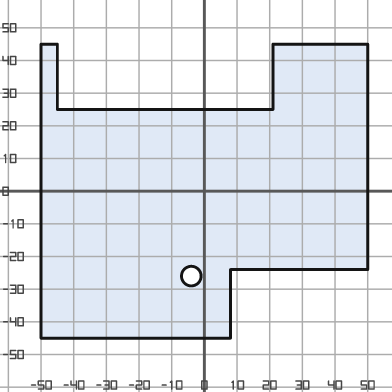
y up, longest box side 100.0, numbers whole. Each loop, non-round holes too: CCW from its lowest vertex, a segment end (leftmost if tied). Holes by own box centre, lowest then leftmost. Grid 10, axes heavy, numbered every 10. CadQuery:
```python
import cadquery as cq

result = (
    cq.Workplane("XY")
    .moveTo(-50.0, -45.0)
    .lineTo(8.0, -45.0)
    .lineTo(8.0, -24.0)
    .lineTo(50.0, -24.0)
    .lineTo(50.0, 45.0)
    .lineTo(21.0, 45.0)
    .lineTo(21.0, 25.0)
    .lineTo(-45.0, 25.0)
    .lineTo(-45.0, 45.0)
    .lineTo(-50.0, 45.0)
    .close()
    .moveTo(-4.0, -26.0)
    .circle(3.0)
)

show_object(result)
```